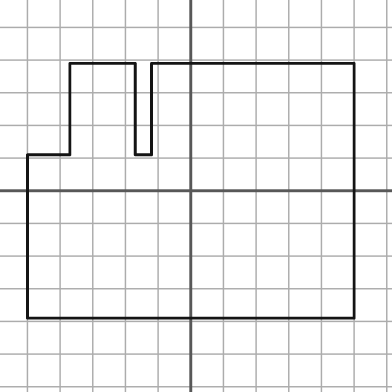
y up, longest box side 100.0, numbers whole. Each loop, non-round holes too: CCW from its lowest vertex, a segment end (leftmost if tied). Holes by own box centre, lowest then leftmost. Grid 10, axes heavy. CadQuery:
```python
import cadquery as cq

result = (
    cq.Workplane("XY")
    .moveTo(-50.0, -39.0)
    .lineTo(50.0, -39.0)
    .lineTo(50.0, 39.0)
    .lineTo(-12.0, 39.0)
    .lineTo(-12.0, 11.0)
    .lineTo(-17.0, 11.0)
    .lineTo(-17.0, 39.0)
    .lineTo(-37.0, 39.0)
    .lineTo(-37.0, 11.0)
    .lineTo(-50.0, 11.0)
    .close()
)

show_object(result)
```